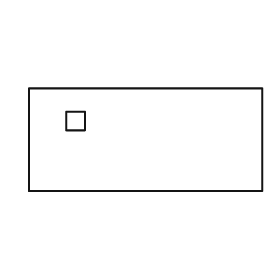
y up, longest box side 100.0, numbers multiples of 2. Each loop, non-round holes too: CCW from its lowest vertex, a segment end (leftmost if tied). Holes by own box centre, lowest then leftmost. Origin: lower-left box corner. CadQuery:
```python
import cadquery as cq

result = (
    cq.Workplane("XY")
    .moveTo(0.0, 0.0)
    .lineTo(100.0, 0.0)
    .lineTo(100.0, 44.0)
    .lineTo(0.0, 44.0)
    .close()
    .moveTo(16.0, 26.0)
    .lineTo(24.0, 26.0)
    .lineTo(24.0, 34.0)
    .lineTo(16.0, 34.0)
    .close()
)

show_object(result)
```